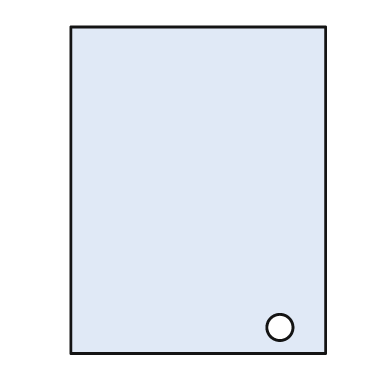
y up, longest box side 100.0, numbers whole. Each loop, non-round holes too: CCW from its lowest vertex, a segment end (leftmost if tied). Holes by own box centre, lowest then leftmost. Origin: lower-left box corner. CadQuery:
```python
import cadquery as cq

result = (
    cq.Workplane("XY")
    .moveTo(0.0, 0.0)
    .lineTo(78.0, 0.0)
    .lineTo(78.0, 100.0)
    .lineTo(0.0, 100.0)
    .close()
    .moveTo(64.0, 8.0)
    .circle(4.0)
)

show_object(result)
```